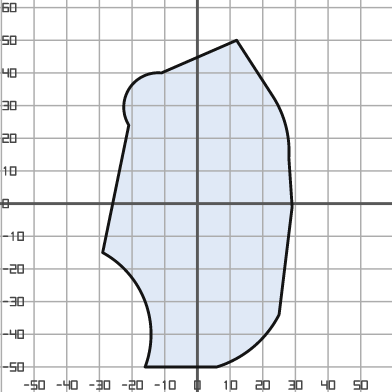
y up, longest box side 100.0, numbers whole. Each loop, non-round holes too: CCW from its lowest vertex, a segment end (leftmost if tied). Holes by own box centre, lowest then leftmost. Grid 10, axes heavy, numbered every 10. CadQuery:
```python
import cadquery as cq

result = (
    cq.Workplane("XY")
    .moveTo(-16.0, -50.0)
    .lineTo(6.0, -50.0)
    .threePointArc((17.0, -44.0), (25.0, -34.0))
    .lineTo(29.0, -1.0)
    .lineTo(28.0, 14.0)
    .threePointArc((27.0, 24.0), (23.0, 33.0))
    .lineTo(12.0, 50.0)
    .lineTo(-11.0, 40.0)
    .threePointArc((-21.0, 35.0), (-21.0, 24.0))
    .lineTo(-29.0, -15.0)
    .threePointArc((-16.0, -30.0), (-16.0, -50.0))
    .close()
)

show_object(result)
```